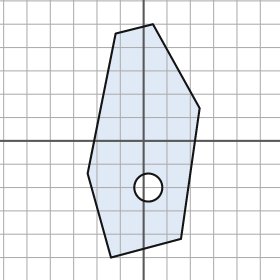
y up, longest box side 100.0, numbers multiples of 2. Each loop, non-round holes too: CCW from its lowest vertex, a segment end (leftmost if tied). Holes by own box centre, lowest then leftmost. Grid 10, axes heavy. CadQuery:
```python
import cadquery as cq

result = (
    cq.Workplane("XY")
    .moveTo(-14.0, -50.0)
    .lineTo(16.0, -42.0)
    .lineTo(24.0, 14.0)
    .lineTo(4.0, 50.0)
    .lineTo(-12.0, 46.0)
    .lineTo(-24.0, -14.0)
    .close()
    .moveTo(2.0, -20.0)
    .circle(6.0)
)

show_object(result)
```